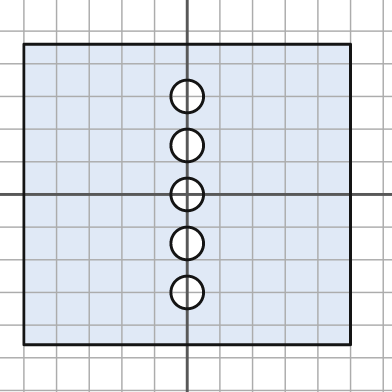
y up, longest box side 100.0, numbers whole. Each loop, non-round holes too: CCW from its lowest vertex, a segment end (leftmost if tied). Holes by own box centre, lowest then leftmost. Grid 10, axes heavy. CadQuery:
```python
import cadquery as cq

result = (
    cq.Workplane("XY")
    .moveTo(-50.0, -46.0)
    .lineTo(50.0, -46.0)
    .lineTo(50.0, 46.0)
    .lineTo(-50.0, 46.0)
    .close()
    .moveTo(0.0, -30.0)
    .circle(5.0)
    .moveTo(0.0, -15.0)
    .circle(5.0)
    .moveTo(0.0, 0.0)
    .circle(5.0)
    .moveTo(0.0, 15.0)
    .circle(5.0)
    .moveTo(0.0, 30.0)
    .circle(5.0)
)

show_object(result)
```